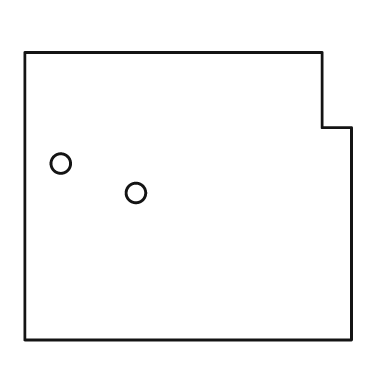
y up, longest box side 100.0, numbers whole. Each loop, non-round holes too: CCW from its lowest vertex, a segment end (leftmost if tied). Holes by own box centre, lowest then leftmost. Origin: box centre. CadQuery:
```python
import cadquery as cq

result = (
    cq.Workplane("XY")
    .moveTo(-50.0, -44.0)
    .lineTo(50.0, -44.0)
    .lineTo(50.0, 21.0)
    .lineTo(41.0, 21.0)
    .lineTo(41.0, 44.0)
    .lineTo(-50.0, 44.0)
    .close()
    .moveTo(-16.0, 1.0)
    .circle(3.0)
    .moveTo(-39.0, 10.0)
    .circle(3.0)
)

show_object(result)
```